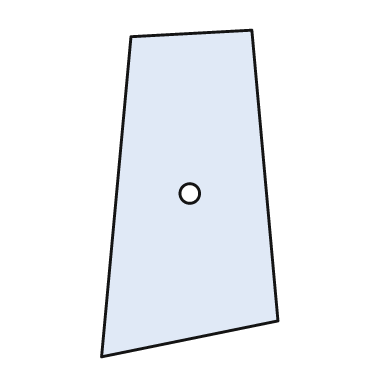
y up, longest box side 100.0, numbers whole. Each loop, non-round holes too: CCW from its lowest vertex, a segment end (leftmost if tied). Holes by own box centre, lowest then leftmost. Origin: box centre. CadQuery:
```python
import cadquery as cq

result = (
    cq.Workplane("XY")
    .moveTo(-27.0, -50.0)
    .lineTo(27.0, -39.0)
    .lineTo(19.0, 50.0)
    .lineTo(-18.0, 48.0)
    .close()
    .moveTo(0.0, 0.0)
    .circle(3.0)
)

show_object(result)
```